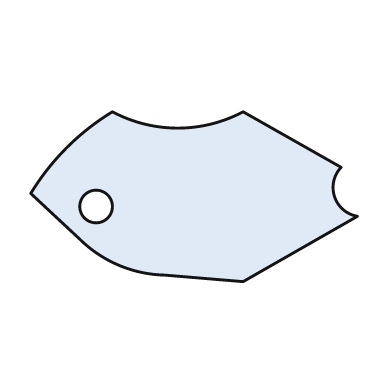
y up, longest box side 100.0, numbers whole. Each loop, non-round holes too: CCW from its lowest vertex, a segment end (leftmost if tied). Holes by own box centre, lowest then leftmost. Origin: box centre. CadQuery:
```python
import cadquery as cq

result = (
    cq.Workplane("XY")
    .moveTo(15.0, -26.0)
    .lineTo(50.0, -6.0)
    .threePointArc((43.0, 0.0), (45.0, 9.0))
    .lineTo(15.0, 26.0)
    .threePointArc((-5.0, 21.0), (-25.0, 26.0))
    .threePointArc((-39.0, 15.0), (-50.0, 1.0))
    .lineTo(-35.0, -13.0)
    .threePointArc((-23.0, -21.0), (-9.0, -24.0))
    .close()
    .moveTo(-30.0, -3.0)
    .circle(5.0)
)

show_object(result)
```